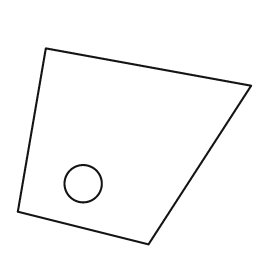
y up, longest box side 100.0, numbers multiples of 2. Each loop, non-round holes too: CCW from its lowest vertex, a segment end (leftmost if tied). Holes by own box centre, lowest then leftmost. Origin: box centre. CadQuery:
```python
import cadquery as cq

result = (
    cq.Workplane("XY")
    .moveTo(6.0, -42.0)
    .lineTo(50.0, 26.0)
    .lineTo(-38.0, 42.0)
    .lineTo(-50.0, -28.0)
    .close()
    .moveTo(-22.0, -16.0)
    .circle(8.0)
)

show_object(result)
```